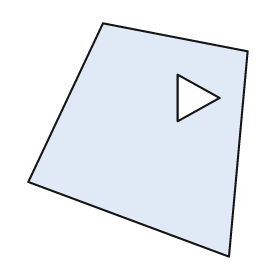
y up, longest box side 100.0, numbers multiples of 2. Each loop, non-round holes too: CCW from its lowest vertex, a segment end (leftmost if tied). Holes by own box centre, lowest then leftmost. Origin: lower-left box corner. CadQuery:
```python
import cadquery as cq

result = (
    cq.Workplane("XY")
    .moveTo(86.0, 0.0)
    .lineTo(94.0, 88.0)
    .lineTo(32.0, 100.0)
    .lineTo(0.0, 32.0)
    .close()
    .moveTo(64.0, 58.0)
    .lineTo(82.0, 68.0)
    .lineTo(64.0, 78.0)
    .close()
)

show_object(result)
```